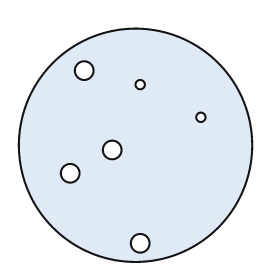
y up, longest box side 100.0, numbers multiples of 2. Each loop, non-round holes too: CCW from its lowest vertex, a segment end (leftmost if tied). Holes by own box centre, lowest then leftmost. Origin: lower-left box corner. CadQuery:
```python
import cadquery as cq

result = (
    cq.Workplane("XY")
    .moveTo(50.0, 50.0)
    .circle(50.0)
    .moveTo(52.0, 8.0)
    .circle(4.0)
    .moveTo(22.0, 38.0)
    .circle(4.0)
    .moveTo(40.0, 48.0)
    .circle(4.0)
    .moveTo(78.0, 62.0)
    .circle(2.0)
    .moveTo(52.0, 76.0)
    .circle(2.0)
    .moveTo(28.0, 82.0)
    .circle(4.0)
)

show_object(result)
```